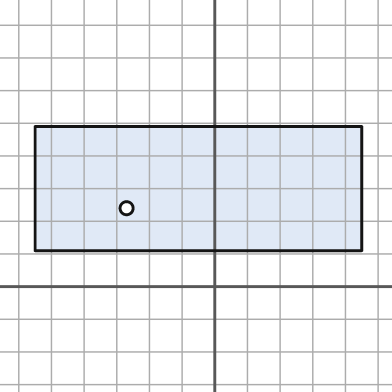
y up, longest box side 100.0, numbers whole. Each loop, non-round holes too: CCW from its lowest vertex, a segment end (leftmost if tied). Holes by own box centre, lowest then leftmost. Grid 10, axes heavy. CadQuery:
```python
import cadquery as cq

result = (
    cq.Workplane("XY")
    .moveTo(-55.0, 11.0)
    .lineTo(45.0, 11.0)
    .lineTo(45.0, 49.0)
    .lineTo(-55.0, 49.0)
    .close()
    .moveTo(-27.0, 24.0)
    .circle(2.0)
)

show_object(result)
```